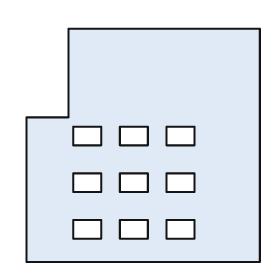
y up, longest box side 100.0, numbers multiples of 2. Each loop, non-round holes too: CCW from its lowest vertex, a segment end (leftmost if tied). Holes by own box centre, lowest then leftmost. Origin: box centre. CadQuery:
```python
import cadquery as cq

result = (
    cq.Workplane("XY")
    .moveTo(-50.0, -50.0)
    .lineTo(50.0, -50.0)
    .lineTo(50.0, 50.0)
    .lineTo(-32.0, 50.0)
    .lineTo(-32.0, 12.0)
    .lineTo(-50.0, 12.0)
    .close()
    .moveTo(-30.0, -40.0)
    .lineTo(-18.0, -40.0)
    .lineTo(-18.0, -32.0)
    .lineTo(-30.0, -32.0)
    .close()
    .moveTo(-10.0, -40.0)
    .lineTo(2.0, -40.0)
    .lineTo(2.0, -32.0)
    .lineTo(-10.0, -32.0)
    .close()
    .moveTo(10.0, -40.0)
    .lineTo(22.0, -40.0)
    .lineTo(22.0, -32.0)
    .lineTo(10.0, -32.0)
    .close()
    .moveTo(-30.0, -20.0)
    .lineTo(-18.0, -20.0)
    .lineTo(-18.0, -12.0)
    .lineTo(-30.0, -12.0)
    .close()
    .moveTo(-10.0, -20.0)
    .lineTo(2.0, -20.0)
    .lineTo(2.0, -12.0)
    .lineTo(-10.0, -12.0)
    .close()
    .moveTo(10.0, -20.0)
    .lineTo(22.0, -20.0)
    .lineTo(22.0, -12.0)
    .lineTo(10.0, -12.0)
    .close()
    .moveTo(-30.0, 0.0)
    .lineTo(-18.0, 0.0)
    .lineTo(-18.0, 8.0)
    .lineTo(-30.0, 8.0)
    .close()
    .moveTo(-10.0, 0.0)
    .lineTo(2.0, 0.0)
    .lineTo(2.0, 8.0)
    .lineTo(-10.0, 8.0)
    .close()
    .moveTo(10.0, 0.0)
    .lineTo(22.0, 0.0)
    .lineTo(22.0, 8.0)
    .lineTo(10.0, 8.0)
    .close()
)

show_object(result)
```